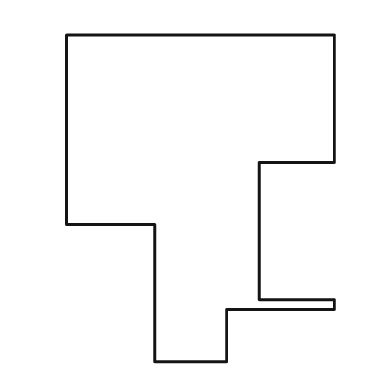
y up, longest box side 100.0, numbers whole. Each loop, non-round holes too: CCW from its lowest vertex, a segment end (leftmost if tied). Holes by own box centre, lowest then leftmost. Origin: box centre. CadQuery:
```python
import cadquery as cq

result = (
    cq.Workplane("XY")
    .moveTo(-14.0, -50.0)
    .lineTo(8.0, -50.0)
    .lineTo(8.0, -34.0)
    .lineTo(41.0, -34.0)
    .lineTo(41.0, -31.0)
    .lineTo(18.0, -31.0)
    .lineTo(18.0, 11.0)
    .lineTo(41.0, 11.0)
    .lineTo(41.0, 50.0)
    .lineTo(-41.0, 50.0)
    .lineTo(-41.0, -8.0)
    .lineTo(-14.0, -8.0)
    .close()
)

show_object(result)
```